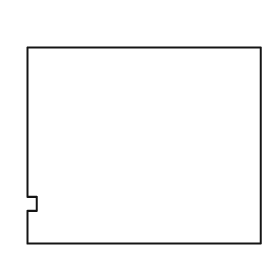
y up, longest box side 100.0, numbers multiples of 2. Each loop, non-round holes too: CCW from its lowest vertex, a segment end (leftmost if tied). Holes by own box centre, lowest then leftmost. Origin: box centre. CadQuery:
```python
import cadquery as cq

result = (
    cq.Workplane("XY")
    .moveTo(-50.0, -42.0)
    .lineTo(50.0, -42.0)
    .lineTo(50.0, 42.0)
    .lineTo(-50.0, 42.0)
    .lineTo(-50.0, -22.0)
    .lineTo(-46.0, -22.0)
    .lineTo(-46.0, -28.0)
    .lineTo(-50.0, -28.0)
    .close()
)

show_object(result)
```